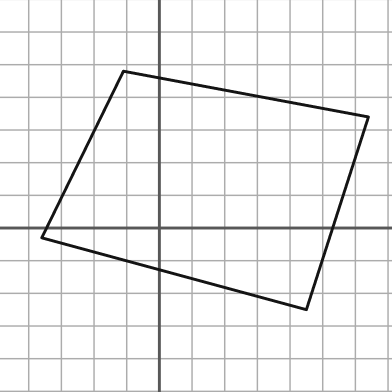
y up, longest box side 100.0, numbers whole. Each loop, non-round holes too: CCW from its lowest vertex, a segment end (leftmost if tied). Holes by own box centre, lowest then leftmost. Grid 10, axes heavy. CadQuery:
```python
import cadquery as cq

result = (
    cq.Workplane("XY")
    .moveTo(45.0, -25.0)
    .lineTo(64.0, 34.0)
    .lineTo(-11.0, 48.0)
    .lineTo(-36.0, -3.0)
    .close()
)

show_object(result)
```